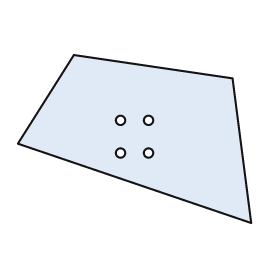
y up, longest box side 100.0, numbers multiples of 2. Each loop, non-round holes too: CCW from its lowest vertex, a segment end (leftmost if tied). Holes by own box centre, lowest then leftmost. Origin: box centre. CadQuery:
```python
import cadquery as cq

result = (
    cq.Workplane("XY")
    .moveTo(50.0, -36.0)
    .lineTo(42.0, 26.0)
    .lineTo(-26.0, 36.0)
    .lineTo(-50.0, -2.0)
    .close()
    .moveTo(-6.0, -6.0)
    .circle(2.0)
    .moveTo(6.0, -6.0)
    .circle(2.0)
    .moveTo(-6.0, 8.0)
    .circle(2.0)
    .moveTo(6.0, 8.0)
    .circle(2.0)
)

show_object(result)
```